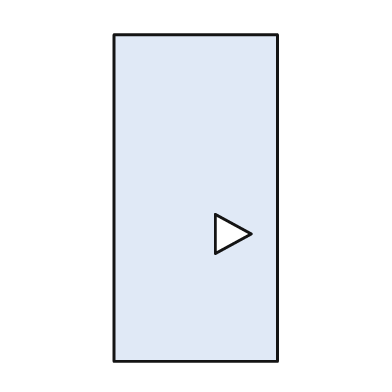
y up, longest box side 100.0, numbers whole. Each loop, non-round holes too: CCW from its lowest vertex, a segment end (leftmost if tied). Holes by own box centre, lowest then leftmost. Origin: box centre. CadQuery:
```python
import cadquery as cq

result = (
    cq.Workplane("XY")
    .moveTo(-25.0, -50.0)
    .lineTo(25.0, -50.0)
    .lineTo(25.0, 50.0)
    .lineTo(-25.0, 50.0)
    .close()
    .moveTo(6.0, -17.0)
    .lineTo(17.0, -11.0)
    .lineTo(6.0, -5.0)
    .close()
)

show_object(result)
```